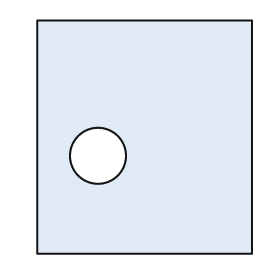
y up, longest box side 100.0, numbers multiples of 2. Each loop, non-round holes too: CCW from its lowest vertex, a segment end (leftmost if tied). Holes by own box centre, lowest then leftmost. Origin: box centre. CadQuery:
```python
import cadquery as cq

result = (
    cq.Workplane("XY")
    .moveTo(-46.0, -50.0)
    .lineTo(46.0, -50.0)
    .lineTo(46.0, 50.0)
    .lineTo(-46.0, 50.0)
    .close()
    .moveTo(-20.0, -8.0)
    .circle(12.0)
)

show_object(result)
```